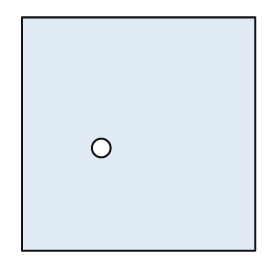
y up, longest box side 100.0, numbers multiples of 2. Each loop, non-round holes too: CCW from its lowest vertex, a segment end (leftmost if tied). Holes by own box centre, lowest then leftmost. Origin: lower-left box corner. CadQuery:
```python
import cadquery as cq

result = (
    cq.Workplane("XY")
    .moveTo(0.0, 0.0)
    .lineTo(100.0, 0.0)
    .lineTo(100.0, 100.0)
    .lineTo(0.0, 100.0)
    .close()
    .moveTo(34.0, 44.0)
    .circle(4.0)
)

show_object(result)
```